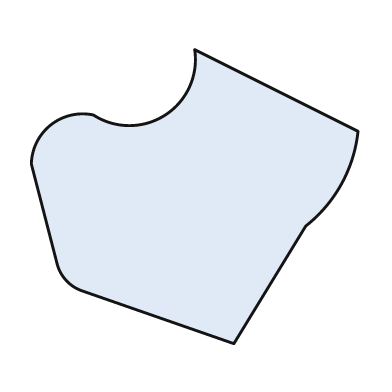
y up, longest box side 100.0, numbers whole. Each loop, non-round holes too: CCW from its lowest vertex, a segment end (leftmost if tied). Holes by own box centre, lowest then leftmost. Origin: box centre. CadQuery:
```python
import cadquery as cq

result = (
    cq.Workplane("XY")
    .moveTo(12.0, -45.0)
    .lineTo(34.0, -9.0)
    .threePointArc((45.0, 4.0), (50.0, 20.0))
    .lineTo(0.0, 45.0)
    .threePointArc((-9.0, 25.0), (-31.0, 25.0))
    .threePointArc((-44.0, 22.0), (-50.0, 10.0))
    .lineTo(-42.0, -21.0)
    .threePointArc((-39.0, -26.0), (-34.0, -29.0))
    .close()
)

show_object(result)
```